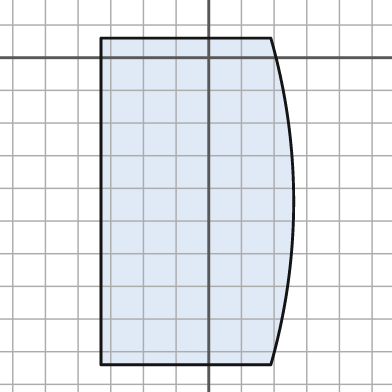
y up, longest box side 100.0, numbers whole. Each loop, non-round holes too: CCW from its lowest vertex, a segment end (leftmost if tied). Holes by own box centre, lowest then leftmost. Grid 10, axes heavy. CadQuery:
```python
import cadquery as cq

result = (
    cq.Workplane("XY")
    .moveTo(-33.0, -94.0)
    .lineTo(19.0, -94.0)
    .threePointArc((26.0, -44.0), (19.0, 6.0))
    .lineTo(-33.0, 6.0)
    .close()
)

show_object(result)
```